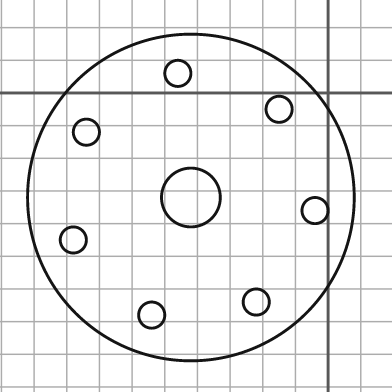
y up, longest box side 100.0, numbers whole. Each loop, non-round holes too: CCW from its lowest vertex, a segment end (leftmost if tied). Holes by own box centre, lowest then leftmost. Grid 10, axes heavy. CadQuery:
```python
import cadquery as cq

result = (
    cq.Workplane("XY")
    .moveTo(-42.0, -32.0)
    .circle(50.0)
    .moveTo(-54.0, -68.0)
    .circle(4.0)
    .moveTo(-22.0, -64.0)
    .circle(4.0)
    .moveTo(-78.0, -45.0)
    .circle(4.0)
    .moveTo(-4.0, -36.0)
    .circle(4.0)
    .moveTo(-42.0, -32.0)
    .circle(9.0)
    .moveTo(-74.0, -12.0)
    .circle(4.0)
    .moveTo(-15.0, -5.0)
    .circle(4.0)
    .moveTo(-46.0, 6.0)
    .circle(4.0)
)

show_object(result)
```